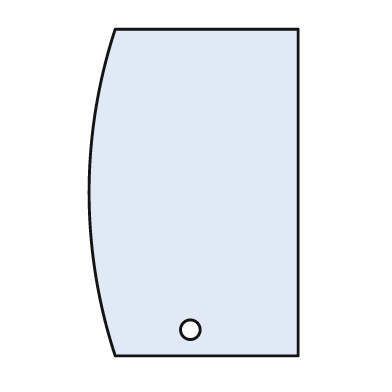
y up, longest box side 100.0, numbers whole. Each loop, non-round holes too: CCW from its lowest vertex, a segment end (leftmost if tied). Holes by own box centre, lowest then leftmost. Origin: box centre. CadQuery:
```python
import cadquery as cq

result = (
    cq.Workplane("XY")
    .moveTo(-24.0, -50.0)
    .lineTo(32.0, -50.0)
    .lineTo(32.0, 50.0)
    .lineTo(-24.0, 50.0)
    .threePointArc((-32.0, 0.0), (-24.0, -50.0))
    .close()
    .moveTo(-1.0, -42.0)
    .circle(3.0)
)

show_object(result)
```